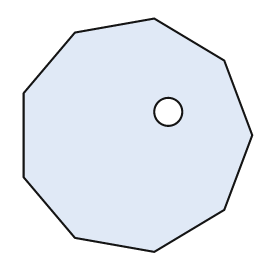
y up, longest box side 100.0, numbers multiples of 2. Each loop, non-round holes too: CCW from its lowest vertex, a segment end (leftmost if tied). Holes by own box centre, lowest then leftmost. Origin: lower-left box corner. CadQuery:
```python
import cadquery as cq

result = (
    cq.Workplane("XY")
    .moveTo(56.0, 0.0)
    .lineTo(86.0, 18.0)
    .lineTo(98.0, 50.0)
    .lineTo(86.0, 82.0)
    .lineTo(56.0, 100.0)
    .lineTo(22.0, 94.0)
    .lineTo(0.0, 68.0)
    .lineTo(0.0, 32.0)
    .lineTo(22.0, 6.0)
    .close()
    .moveTo(62.0, 60.0)
    .circle(6.0)
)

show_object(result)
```